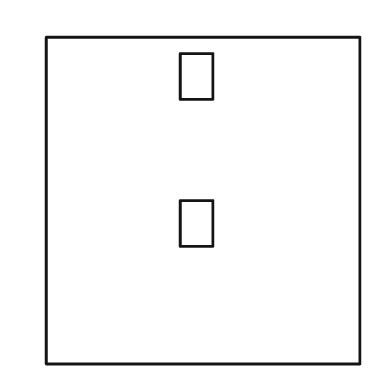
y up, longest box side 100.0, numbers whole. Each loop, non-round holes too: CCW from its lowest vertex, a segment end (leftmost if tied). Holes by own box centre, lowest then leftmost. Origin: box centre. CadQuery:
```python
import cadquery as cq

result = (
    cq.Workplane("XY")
    .moveTo(-48.0, -50.0)
    .lineTo(48.0, -50.0)
    .lineTo(48.0, 50.0)
    .lineTo(-48.0, 50.0)
    .close()
    .moveTo(-7.0, -14.0)
    .lineTo(3.0, -14.0)
    .lineTo(3.0, 0.0)
    .lineTo(-7.0, 0.0)
    .close()
    .moveTo(-7.0, 31.0)
    .lineTo(3.0, 31.0)
    .lineTo(3.0, 45.0)
    .lineTo(-7.0, 45.0)
    .close()
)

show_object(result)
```